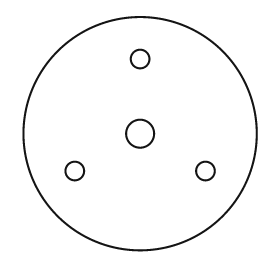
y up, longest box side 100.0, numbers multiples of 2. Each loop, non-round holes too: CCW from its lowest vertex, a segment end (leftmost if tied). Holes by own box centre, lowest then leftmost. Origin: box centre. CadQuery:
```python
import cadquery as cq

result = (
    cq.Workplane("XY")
    .moveTo(0.0, 0.0)
    .circle(50.0)
    .moveTo(-28.0, -16.0)
    .circle(4.0)
    .moveTo(28.0, -16.0)
    .circle(4.0)
    .moveTo(0.0, 0.0)
    .circle(6.0)
    .moveTo(0.0, 32.0)
    .circle(4.0)
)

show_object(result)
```